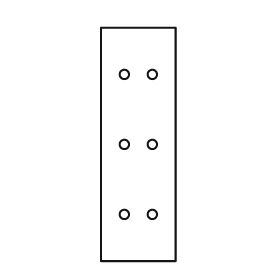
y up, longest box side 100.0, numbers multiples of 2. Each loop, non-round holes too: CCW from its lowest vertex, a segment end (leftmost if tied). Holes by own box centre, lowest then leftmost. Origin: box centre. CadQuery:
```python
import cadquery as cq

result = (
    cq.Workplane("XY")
    .moveTo(-16.0, -50.0)
    .lineTo(16.0, -50.0)
    .lineTo(16.0, 50.0)
    .lineTo(-16.0, 50.0)
    .close()
    .moveTo(-6.0, -30.0)
    .circle(2.0)
    .moveTo(6.0, -30.0)
    .circle(2.0)
    .moveTo(-6.0, 0.0)
    .circle(2.0)
    .moveTo(6.0, 0.0)
    .circle(2.0)
    .moveTo(-6.0, 30.0)
    .circle(2.0)
    .moveTo(6.0, 30.0)
    .circle(2.0)
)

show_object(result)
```